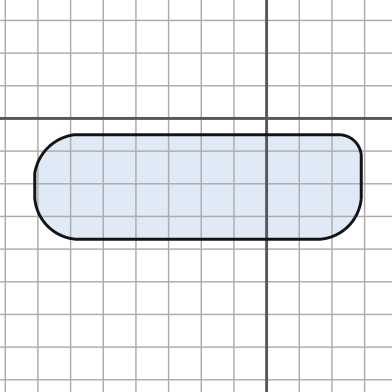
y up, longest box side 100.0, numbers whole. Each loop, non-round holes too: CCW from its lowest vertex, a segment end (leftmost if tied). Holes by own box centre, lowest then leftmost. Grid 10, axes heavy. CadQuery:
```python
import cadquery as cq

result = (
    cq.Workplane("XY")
    .moveTo(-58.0, -37.0)
    .lineTo(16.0, -37.0)
    .threePointArc((25.0, -33.0), (29.0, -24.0))
    .lineTo(29.0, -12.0)
    .threePointArc((27.0, -7.0), (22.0, -5.0))
    .lineTo(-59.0, -5.0)
    .threePointArc((-67.0, -9.0), (-71.0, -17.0))
    .lineTo(-71.0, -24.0)
    .threePointArc((-67.0, -33.0), (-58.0, -37.0))
    .close()
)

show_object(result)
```